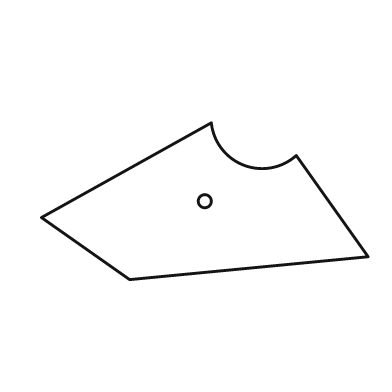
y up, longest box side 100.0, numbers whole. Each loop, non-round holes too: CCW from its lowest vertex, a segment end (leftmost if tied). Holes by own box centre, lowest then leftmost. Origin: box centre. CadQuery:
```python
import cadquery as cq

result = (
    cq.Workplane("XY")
    .moveTo(-23.0, -24.0)
    .lineTo(50.0, -17.0)
    .lineTo(28.0, 14.0)
    .threePointArc((12.0, 11.0), (2.0, 24.0))
    .lineTo(-50.0, -5.0)
    .close()
    .moveTo(0.0, 0.0)
    .circle(2.0)
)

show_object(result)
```